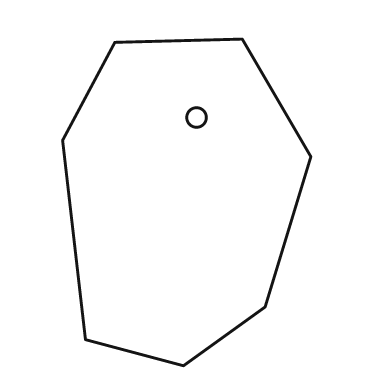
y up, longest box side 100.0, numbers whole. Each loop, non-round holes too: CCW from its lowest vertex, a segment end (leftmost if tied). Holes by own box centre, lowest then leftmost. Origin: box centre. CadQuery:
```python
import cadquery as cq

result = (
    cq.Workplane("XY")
    .moveTo(-1.0, -50.0)
    .lineTo(24.0, -32.0)
    .lineTo(38.0, 14.0)
    .lineTo(17.0, 50.0)
    .lineTo(-22.0, 49.0)
    .lineTo(-38.0, 19.0)
    .lineTo(-31.0, -42.0)
    .close()
    .moveTo(3.0, 26.0)
    .circle(3.0)
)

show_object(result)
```